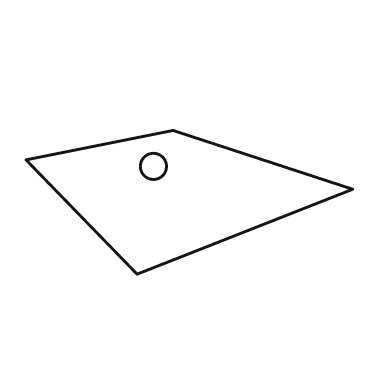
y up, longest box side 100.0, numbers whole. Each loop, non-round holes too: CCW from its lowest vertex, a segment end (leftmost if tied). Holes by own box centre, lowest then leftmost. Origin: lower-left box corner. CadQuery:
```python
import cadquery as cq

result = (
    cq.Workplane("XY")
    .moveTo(34.0, 0.0)
    .lineTo(100.0, 26.0)
    .lineTo(45.0, 44.0)
    .lineTo(0.0, 35.0)
    .close()
    .moveTo(39.0, 33.0)
    .circle(4.0)
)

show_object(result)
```